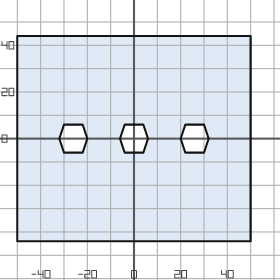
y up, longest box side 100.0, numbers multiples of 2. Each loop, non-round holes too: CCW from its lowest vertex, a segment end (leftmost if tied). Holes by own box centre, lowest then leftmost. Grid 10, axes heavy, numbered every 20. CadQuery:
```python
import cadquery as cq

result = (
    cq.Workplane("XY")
    .moveTo(-50.0, -44.0)
    .lineTo(50.0, -44.0)
    .lineTo(50.0, 44.0)
    .lineTo(-50.0, 44.0)
    .close()
    .moveTo(-30.0, -6.0)
    .lineTo(-22.0, -6.0)
    .lineTo(-20.0, 0.0)
    .lineTo(-22.0, 6.0)
    .lineTo(-30.0, 6.0)
    .lineTo(-32.0, 0.0)
    .close()
    .moveTo(-4.0, -6.0)
    .lineTo(4.0, -6.0)
    .lineTo(6.0, 0.0)
    .lineTo(4.0, 6.0)
    .lineTo(-4.0, 6.0)
    .lineTo(-6.0, 0.0)
    .close()
    .moveTo(22.0, -6.0)
    .lineTo(30.0, -6.0)
    .lineTo(32.0, 0.0)
    .lineTo(30.0, 6.0)
    .lineTo(22.0, 6.0)
    .lineTo(20.0, 0.0)
    .close()
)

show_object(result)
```